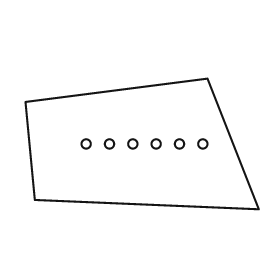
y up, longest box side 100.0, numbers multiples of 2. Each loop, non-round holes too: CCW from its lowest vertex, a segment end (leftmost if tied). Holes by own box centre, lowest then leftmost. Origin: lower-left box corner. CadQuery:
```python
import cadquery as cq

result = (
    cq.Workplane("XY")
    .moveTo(100.0, 0.0)
    .lineTo(78.0, 56.0)
    .lineTo(0.0, 46.0)
    .lineTo(4.0, 4.0)
    .close()
    .moveTo(26.0, 28.0)
    .circle(2.0)
    .moveTo(36.0, 28.0)
    .circle(2.0)
    .moveTo(46.0, 28.0)
    .circle(2.0)
    .moveTo(56.0, 28.0)
    .circle(2.0)
    .moveTo(66.0, 28.0)
    .circle(2.0)
    .moveTo(76.0, 28.0)
    .circle(2.0)
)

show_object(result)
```